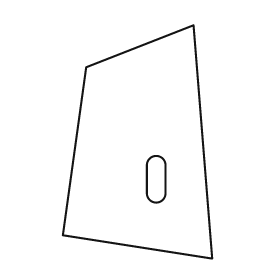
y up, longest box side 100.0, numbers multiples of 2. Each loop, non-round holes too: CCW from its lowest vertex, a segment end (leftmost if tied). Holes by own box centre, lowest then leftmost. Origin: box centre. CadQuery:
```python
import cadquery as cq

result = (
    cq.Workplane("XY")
    .moveTo(32.0, -50.0)
    .lineTo(24.0, 50.0)
    .lineTo(-22.0, 32.0)
    .lineTo(-32.0, -40.0)
    .close()
    .moveTo(4.0, -22.0)
    .threePointArc((8.0, -26.0), (12.0, -22.0))
    .lineTo(12.0, -10.0)
    .threePointArc((8.0, -6.0), (4.0, -10.0))
    .close()
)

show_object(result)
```